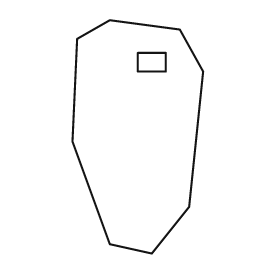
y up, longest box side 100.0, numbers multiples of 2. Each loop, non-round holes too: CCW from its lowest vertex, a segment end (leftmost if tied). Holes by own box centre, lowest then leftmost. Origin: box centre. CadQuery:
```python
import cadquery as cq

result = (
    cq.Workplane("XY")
    .moveTo(6.0, -50.0)
    .lineTo(22.0, -30.0)
    .lineTo(28.0, 28.0)
    .lineTo(18.0, 46.0)
    .lineTo(-12.0, 50.0)
    .lineTo(-26.0, 42.0)
    .lineTo(-28.0, -2.0)
    .lineTo(-12.0, -46.0)
    .close()
    .moveTo(0.0, 28.0)
    .lineTo(12.0, 28.0)
    .lineTo(12.0, 36.0)
    .lineTo(0.0, 36.0)
    .close()
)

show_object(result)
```